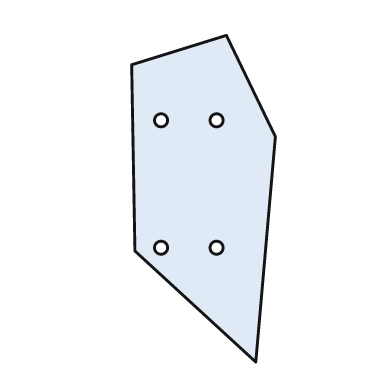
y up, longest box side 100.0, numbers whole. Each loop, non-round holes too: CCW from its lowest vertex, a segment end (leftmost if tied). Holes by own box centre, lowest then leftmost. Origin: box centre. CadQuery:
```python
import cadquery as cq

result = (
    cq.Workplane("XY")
    .moveTo(16.0, -50.0)
    .lineTo(22.0, 19.0)
    .lineTo(7.0, 50.0)
    .lineTo(-22.0, 41.0)
    .lineTo(-21.0, -16.0)
    .close()
    .moveTo(-13.0, -15.0)
    .circle(2.0)
    .moveTo(4.0, -15.0)
    .circle(2.0)
    .moveTo(-13.0, 24.0)
    .circle(2.0)
    .moveTo(4.0, 24.0)
    .circle(2.0)
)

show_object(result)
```